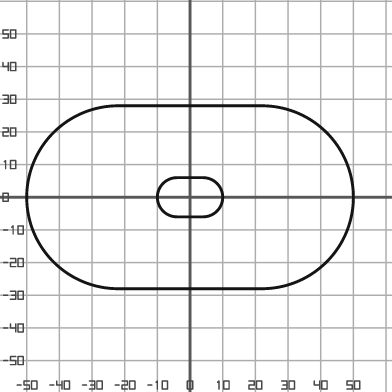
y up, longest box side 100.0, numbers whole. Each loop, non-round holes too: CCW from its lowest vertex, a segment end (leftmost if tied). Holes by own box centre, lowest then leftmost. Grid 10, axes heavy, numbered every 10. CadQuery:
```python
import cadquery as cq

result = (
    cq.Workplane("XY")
    .moveTo(-22.0, -28.0)
    .lineTo(22.0, -28.0)
    .threePointArc((50.0, 0.0), (22.0, 28.0))
    .lineTo(-22.0, 28.0)
    .threePointArc((-50.0, 0.0), (-22.0, -28.0))
    .close()
    .moveTo(-4.0, -6.0)
    .lineTo(4.0, -6.0)
    .threePointArc((10.0, 0.0), (4.0, 6.0))
    .lineTo(-4.0, 6.0)
    .threePointArc((-10.0, 0.0), (-4.0, -6.0))
    .close()
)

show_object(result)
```